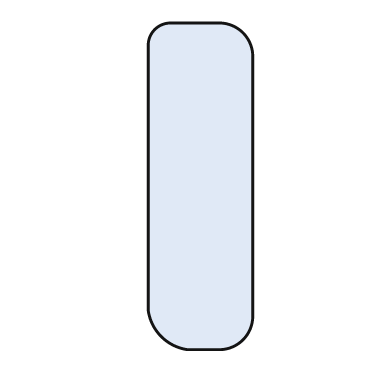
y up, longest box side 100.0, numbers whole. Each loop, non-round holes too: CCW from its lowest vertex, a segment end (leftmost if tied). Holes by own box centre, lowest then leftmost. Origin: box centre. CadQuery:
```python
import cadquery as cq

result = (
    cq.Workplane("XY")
    .moveTo(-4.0, -50.0)
    .lineTo(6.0, -50.0)
    .threePointArc((13.0, -47.0), (16.0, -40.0))
    .lineTo(16.0, 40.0)
    .threePointArc((13.0, 47.0), (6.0, 50.0))
    .lineTo(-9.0, 50.0)
    .threePointArc((-14.0, 48.0), (-16.0, 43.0))
    .lineTo(-16.0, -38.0)
    .threePointArc((-12.0, -46.0), (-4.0, -50.0))
    .close()
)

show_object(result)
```